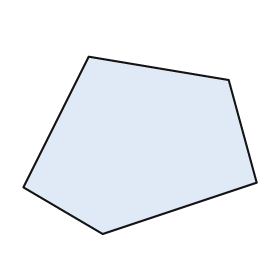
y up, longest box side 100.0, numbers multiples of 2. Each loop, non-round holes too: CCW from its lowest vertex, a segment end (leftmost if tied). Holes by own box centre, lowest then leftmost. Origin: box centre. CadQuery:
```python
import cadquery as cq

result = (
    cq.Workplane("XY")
    .moveTo(-16.0, -38.0)
    .lineTo(50.0, -16.0)
    .lineTo(38.0, 28.0)
    .lineTo(-22.0, 38.0)
    .lineTo(-50.0, -18.0)
    .close()
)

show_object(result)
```